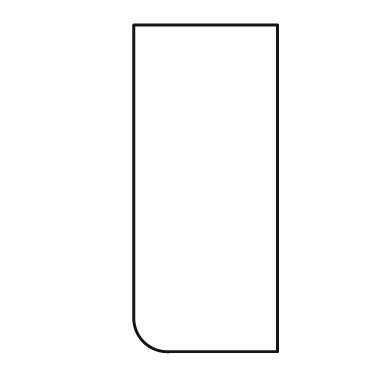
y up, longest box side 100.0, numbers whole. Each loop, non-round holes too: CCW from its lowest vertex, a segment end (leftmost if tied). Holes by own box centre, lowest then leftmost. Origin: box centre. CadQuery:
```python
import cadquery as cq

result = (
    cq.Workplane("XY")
    .moveTo(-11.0, -50.0)
    .lineTo(22.0, -50.0)
    .lineTo(22.0, 50.0)
    .lineTo(-22.0, 50.0)
    .lineTo(-22.0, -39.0)
    .threePointArc((-19.0, -47.0), (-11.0, -50.0))
    .close()
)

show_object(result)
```